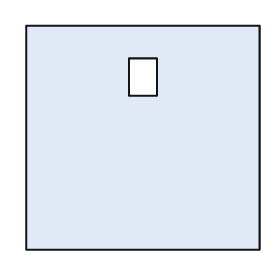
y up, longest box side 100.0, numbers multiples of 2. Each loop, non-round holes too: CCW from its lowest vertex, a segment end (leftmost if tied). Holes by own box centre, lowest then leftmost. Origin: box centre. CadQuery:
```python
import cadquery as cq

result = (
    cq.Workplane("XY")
    .moveTo(-50.0, -48.0)
    .lineTo(50.0, -48.0)
    .lineTo(50.0, 48.0)
    .lineTo(-50.0, 48.0)
    .close()
    .moveTo(-6.0, 18.0)
    .lineTo(6.0, 18.0)
    .lineTo(6.0, 34.0)
    .lineTo(-6.0, 34.0)
    .close()
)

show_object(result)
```